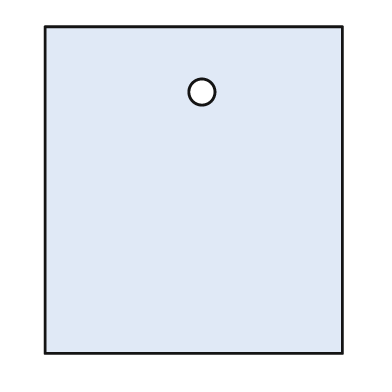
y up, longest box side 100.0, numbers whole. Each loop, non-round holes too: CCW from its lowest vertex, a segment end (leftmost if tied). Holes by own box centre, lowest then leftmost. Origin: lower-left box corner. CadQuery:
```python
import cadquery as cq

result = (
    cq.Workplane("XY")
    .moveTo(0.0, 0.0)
    .lineTo(91.0, 0.0)
    .lineTo(91.0, 100.0)
    .lineTo(0.0, 100.0)
    .close()
    .moveTo(48.0, 80.0)
    .circle(4.0)
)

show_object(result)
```